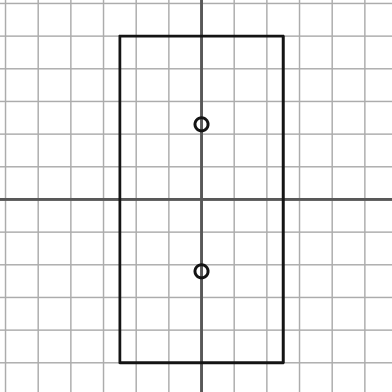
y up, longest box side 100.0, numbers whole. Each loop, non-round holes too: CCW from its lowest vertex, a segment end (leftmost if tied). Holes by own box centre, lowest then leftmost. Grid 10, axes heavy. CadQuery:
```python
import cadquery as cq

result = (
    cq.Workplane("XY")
    .moveTo(-25.0, -50.0)
    .lineTo(25.0, -50.0)
    .lineTo(25.0, 50.0)
    .lineTo(-25.0, 50.0)
    .close()
    .moveTo(0.0, -22.0)
    .circle(2.0)
    .moveTo(0.0, 23.0)
    .circle(2.0)
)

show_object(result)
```